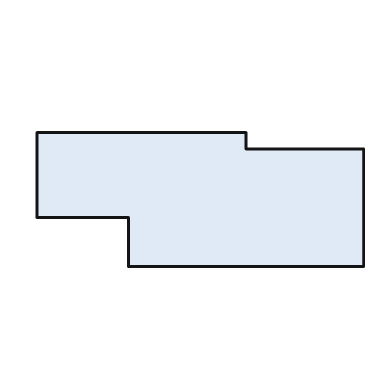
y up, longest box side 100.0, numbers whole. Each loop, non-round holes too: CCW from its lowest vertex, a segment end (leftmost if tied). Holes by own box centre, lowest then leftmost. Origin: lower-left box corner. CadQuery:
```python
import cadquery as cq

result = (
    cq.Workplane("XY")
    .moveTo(28.0, 0.0)
    .lineTo(100.0, 0.0)
    .lineTo(100.0, 36.0)
    .lineTo(64.0, 36.0)
    .lineTo(64.0, 41.0)
    .lineTo(0.0, 41.0)
    .lineTo(0.0, 15.0)
    .lineTo(28.0, 15.0)
    .close()
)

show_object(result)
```